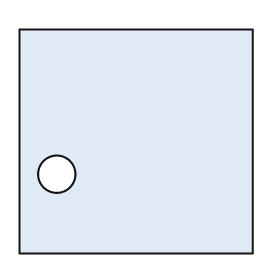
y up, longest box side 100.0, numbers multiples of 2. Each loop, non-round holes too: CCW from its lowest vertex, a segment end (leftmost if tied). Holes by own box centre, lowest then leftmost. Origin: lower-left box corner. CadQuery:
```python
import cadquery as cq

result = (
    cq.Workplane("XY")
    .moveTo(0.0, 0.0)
    .lineTo(100.0, 0.0)
    .lineTo(100.0, 96.0)
    .lineTo(0.0, 96.0)
    .close()
    .moveTo(16.0, 34.0)
    .circle(8.0)
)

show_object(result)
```